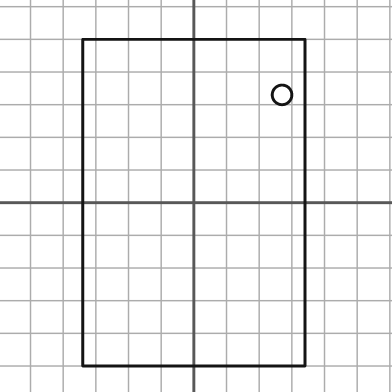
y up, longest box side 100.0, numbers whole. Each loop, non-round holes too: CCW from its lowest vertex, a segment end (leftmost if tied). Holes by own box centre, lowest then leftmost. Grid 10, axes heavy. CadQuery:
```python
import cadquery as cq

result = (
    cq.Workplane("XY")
    .moveTo(-34.0, -50.0)
    .lineTo(34.0, -50.0)
    .lineTo(34.0, 50.0)
    .lineTo(-34.0, 50.0)
    .close()
    .moveTo(27.0, 33.0)
    .circle(3.0)
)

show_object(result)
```